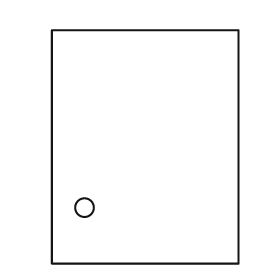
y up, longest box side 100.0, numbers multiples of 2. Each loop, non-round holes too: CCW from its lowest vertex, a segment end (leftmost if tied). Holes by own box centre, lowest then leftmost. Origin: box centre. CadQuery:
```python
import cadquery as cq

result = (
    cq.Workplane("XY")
    .moveTo(-40.0, -50.0)
    .lineTo(40.0, -50.0)
    .lineTo(40.0, 50.0)
    .lineTo(-40.0, 50.0)
    .close()
    .moveTo(-26.0, -26.0)
    .circle(4.0)
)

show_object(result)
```